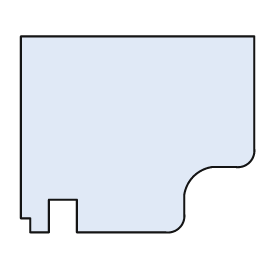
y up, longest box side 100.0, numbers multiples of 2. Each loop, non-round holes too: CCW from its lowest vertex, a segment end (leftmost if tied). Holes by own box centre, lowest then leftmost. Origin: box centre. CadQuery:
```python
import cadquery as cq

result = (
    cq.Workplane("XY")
    .moveTo(-46.0, -42.0)
    .lineTo(-38.0, -42.0)
    .lineTo(-38.0, -28.0)
    .lineTo(-26.0, -28.0)
    .lineTo(-26.0, -42.0)
    .lineTo(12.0, -42.0)
    .threePointArc((18.0, -40.0), (20.0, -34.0))
    .lineTo(20.0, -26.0)
    .threePointArc((24.0, -18.0), (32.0, -14.0))
    .lineTo(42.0, -14.0)
    .threePointArc((48.0, -12.0), (50.0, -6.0))
    .lineTo(50.0, 42.0)
    .lineTo(-50.0, 42.0)
    .lineTo(-50.0, -36.0)
    .lineTo(-46.0, -36.0)
    .close()
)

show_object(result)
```